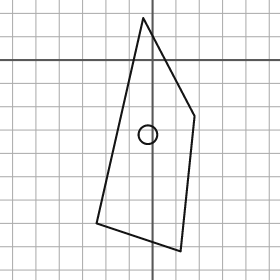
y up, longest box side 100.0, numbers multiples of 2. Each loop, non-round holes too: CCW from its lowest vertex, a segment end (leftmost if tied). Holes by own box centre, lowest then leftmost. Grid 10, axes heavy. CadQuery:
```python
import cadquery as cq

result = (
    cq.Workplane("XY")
    .moveTo(12.0, -82.0)
    .lineTo(18.0, -24.0)
    .lineTo(-4.0, 18.0)
    .lineTo(-24.0, -70.0)
    .close()
    .moveTo(-2.0, -32.0)
    .circle(4.0)
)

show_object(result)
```